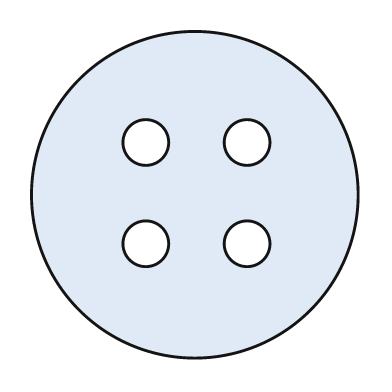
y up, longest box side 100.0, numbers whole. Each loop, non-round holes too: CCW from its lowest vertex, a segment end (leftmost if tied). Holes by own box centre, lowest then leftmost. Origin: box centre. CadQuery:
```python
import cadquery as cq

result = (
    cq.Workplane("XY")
    .moveTo(0.0, 0.0)
    .circle(50.0)
    .moveTo(-15.0, -15.0)
    .circle(7.0)
    .moveTo(16.0, -15.0)
    .circle(7.0)
    .moveTo(-15.0, 16.0)
    .circle(7.0)
    .moveTo(16.0, 16.0)
    .circle(7.0)
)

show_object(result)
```